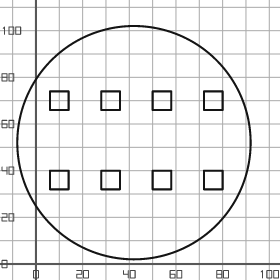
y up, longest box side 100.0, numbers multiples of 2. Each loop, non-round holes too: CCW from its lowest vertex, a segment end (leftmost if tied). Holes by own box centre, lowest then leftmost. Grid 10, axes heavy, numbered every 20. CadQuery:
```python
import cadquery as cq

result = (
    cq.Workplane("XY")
    .moveTo(42.0, 52.0)
    .circle(50.0)
    .moveTo(6.0, 32.0)
    .lineTo(14.0, 32.0)
    .lineTo(14.0, 40.0)
    .lineTo(6.0, 40.0)
    .close()
    .moveTo(28.0, 32.0)
    .lineTo(36.0, 32.0)
    .lineTo(36.0, 40.0)
    .lineTo(28.0, 40.0)
    .close()
    .moveTo(50.0, 32.0)
    .lineTo(58.0, 32.0)
    .lineTo(58.0, 40.0)
    .lineTo(50.0, 40.0)
    .close()
    .moveTo(72.0, 32.0)
    .lineTo(80.0, 32.0)
    .lineTo(80.0, 40.0)
    .lineTo(72.0, 40.0)
    .close()
    .moveTo(6.0, 66.0)
    .lineTo(14.0, 66.0)
    .lineTo(14.0, 74.0)
    .lineTo(6.0, 74.0)
    .close()
    .moveTo(28.0, 66.0)
    .lineTo(36.0, 66.0)
    .lineTo(36.0, 74.0)
    .lineTo(28.0, 74.0)
    .close()
    .moveTo(50.0, 66.0)
    .lineTo(58.0, 66.0)
    .lineTo(58.0, 74.0)
    .lineTo(50.0, 74.0)
    .close()
    .moveTo(72.0, 66.0)
    .lineTo(80.0, 66.0)
    .lineTo(80.0, 74.0)
    .lineTo(72.0, 74.0)
    .close()
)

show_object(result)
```